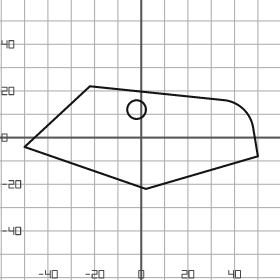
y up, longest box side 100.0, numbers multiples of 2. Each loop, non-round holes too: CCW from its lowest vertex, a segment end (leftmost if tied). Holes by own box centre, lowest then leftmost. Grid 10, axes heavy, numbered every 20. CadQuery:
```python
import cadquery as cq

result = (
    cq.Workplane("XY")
    .moveTo(2.0, -22.0)
    .lineTo(50.0, -8.0)
    .lineTo(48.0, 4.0)
    .threePointArc((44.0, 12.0), (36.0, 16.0))
    .lineTo(-22.0, 22.0)
    .lineTo(-50.0, -4.0)
    .close()
    .moveTo(-2.0, 12.0)
    .circle(4.0)
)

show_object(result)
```